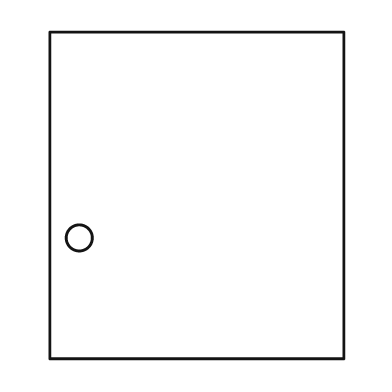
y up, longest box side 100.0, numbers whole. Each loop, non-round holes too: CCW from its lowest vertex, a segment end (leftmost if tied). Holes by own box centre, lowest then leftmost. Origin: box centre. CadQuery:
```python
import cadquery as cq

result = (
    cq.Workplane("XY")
    .moveTo(-45.0, -50.0)
    .lineTo(45.0, -50.0)
    .lineTo(45.0, 50.0)
    .lineTo(-45.0, 50.0)
    .close()
    .moveTo(-36.0, -13.0)
    .circle(4.0)
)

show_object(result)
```